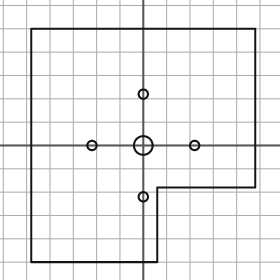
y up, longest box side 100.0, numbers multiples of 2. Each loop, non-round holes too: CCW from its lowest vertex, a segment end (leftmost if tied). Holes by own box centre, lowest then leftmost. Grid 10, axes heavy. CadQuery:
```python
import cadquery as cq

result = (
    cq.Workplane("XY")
    .moveTo(-48.0, -50.0)
    .lineTo(6.0, -50.0)
    .lineTo(6.0, -18.0)
    .lineTo(48.0, -18.0)
    .lineTo(48.0, 50.0)
    .lineTo(-48.0, 50.0)
    .close()
    .moveTo(0.0, -22.0)
    .circle(2.0)
    .moveTo(-22.0, 0.0)
    .circle(2.0)
    .moveTo(0.0, 0.0)
    .circle(4.0)
    .moveTo(22.0, 0.0)
    .circle(2.0)
    .moveTo(0.0, 22.0)
    .circle(2.0)
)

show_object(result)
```